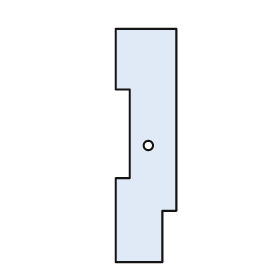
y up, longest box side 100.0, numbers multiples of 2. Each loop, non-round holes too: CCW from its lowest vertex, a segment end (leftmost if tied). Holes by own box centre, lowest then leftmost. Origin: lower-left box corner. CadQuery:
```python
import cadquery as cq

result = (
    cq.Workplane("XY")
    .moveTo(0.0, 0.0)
    .lineTo(20.0, 0.0)
    .lineTo(20.0, 22.0)
    .lineTo(26.0, 22.0)
    .lineTo(26.0, 100.0)
    .lineTo(0.0, 100.0)
    .lineTo(0.0, 74.0)
    .lineTo(6.0, 74.0)
    .lineTo(6.0, 36.0)
    .lineTo(0.0, 36.0)
    .close()
    .moveTo(14.0, 50.0)
    .circle(2.0)
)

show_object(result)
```